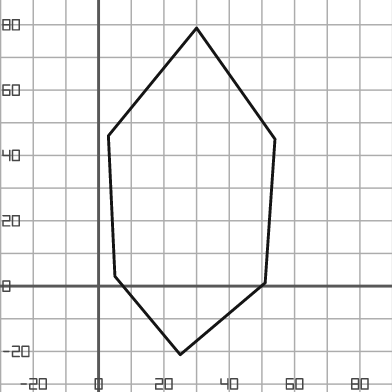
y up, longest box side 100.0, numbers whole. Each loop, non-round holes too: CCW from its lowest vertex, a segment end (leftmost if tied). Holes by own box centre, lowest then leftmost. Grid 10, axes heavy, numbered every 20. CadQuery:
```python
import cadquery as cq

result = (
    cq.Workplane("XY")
    .moveTo(25.0, -21.0)
    .lineTo(51.0, 1.0)
    .lineTo(54.0, 45.0)
    .lineTo(30.0, 79.0)
    .lineTo(3.0, 46.0)
    .lineTo(5.0, 3.0)
    .close()
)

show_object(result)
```